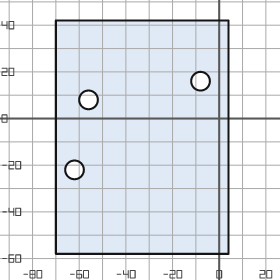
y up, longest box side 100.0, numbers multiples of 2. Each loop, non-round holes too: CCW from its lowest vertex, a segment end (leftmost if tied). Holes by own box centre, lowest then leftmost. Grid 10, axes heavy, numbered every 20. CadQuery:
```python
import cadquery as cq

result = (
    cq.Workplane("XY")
    .moveTo(-70.0, -58.0)
    .lineTo(4.0, -58.0)
    .lineTo(4.0, 42.0)
    .lineTo(-70.0, 42.0)
    .close()
    .moveTo(-62.0, -22.0)
    .circle(4.0)
    .moveTo(-56.0, 8.0)
    .circle(4.0)
    .moveTo(-8.0, 16.0)
    .circle(4.0)
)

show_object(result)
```